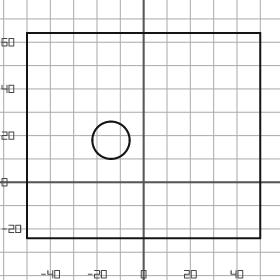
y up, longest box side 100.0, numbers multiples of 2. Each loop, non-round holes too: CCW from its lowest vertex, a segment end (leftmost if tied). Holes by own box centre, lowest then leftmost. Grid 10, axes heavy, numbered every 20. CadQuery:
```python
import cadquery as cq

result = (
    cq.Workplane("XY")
    .moveTo(-50.0, -24.0)
    .lineTo(50.0, -24.0)
    .lineTo(50.0, 64.0)
    .lineTo(-50.0, 64.0)
    .close()
    .moveTo(-14.0, 18.0)
    .circle(8.0)
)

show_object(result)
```